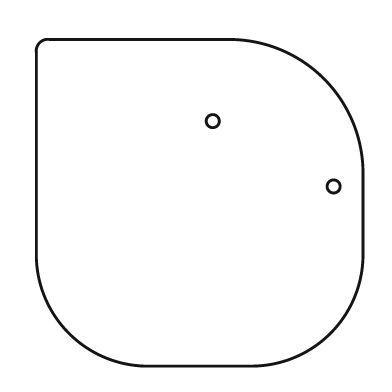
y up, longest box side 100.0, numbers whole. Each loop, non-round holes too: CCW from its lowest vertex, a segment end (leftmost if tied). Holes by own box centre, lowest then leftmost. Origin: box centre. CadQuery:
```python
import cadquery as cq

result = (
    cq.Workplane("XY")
    .moveTo(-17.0, -50.0)
    .lineTo(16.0, -50.0)
    .threePointArc((40.0, -40.0), (50.0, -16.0))
    .lineTo(50.0, 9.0)
    .threePointArc((38.0, 38.0), (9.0, 50.0))
    .lineTo(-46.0, 50.0)
    .threePointArc((-49.0, 49.0), (-50.0, 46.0))
    .lineTo(-50.0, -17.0)
    .threePointArc((-40.0, -40.0), (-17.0, -50.0))
    .close()
    .moveTo(41.0, 5.0)
    .circle(2.0)
    .moveTo(4.0, 25.0)
    .circle(2.0)
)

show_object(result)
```